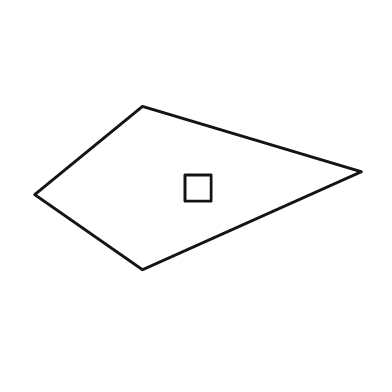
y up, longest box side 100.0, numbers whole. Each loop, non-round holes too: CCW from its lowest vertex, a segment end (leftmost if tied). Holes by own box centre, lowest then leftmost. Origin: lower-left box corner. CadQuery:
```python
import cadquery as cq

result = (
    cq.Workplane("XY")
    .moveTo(33.0, 0.0)
    .lineTo(100.0, 30.0)
    .lineTo(33.0, 50.0)
    .lineTo(0.0, 23.0)
    .close()
    .moveTo(46.0, 21.0)
    .lineTo(54.0, 21.0)
    .lineTo(54.0, 29.0)
    .lineTo(46.0, 29.0)
    .close()
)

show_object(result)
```